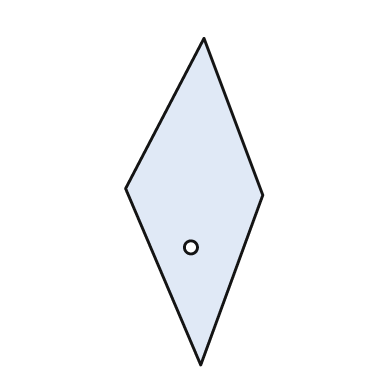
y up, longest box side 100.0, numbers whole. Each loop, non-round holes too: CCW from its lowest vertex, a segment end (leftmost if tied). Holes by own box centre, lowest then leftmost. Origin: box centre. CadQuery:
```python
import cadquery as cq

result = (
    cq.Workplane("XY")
    .moveTo(2.0, -50.0)
    .lineTo(21.0, 2.0)
    .lineTo(3.0, 50.0)
    .lineTo(-21.0, 4.0)
    .close()
    .moveTo(-1.0, -14.0)
    .circle(2.0)
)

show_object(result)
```